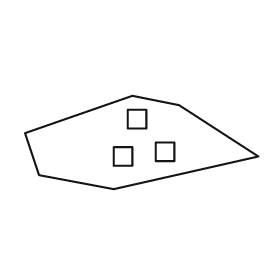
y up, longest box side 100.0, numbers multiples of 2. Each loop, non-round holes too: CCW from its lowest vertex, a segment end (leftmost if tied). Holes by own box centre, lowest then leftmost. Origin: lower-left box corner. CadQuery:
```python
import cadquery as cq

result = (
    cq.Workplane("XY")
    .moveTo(38.0, 0.0)
    .lineTo(100.0, 14.0)
    .lineTo(66.0, 36.0)
    .lineTo(46.0, 40.0)
    .lineTo(0.0, 24.0)
    .lineTo(6.0, 6.0)
    .close()
    .moveTo(38.0, 10.0)
    .lineTo(46.0, 10.0)
    .lineTo(46.0, 18.0)
    .lineTo(38.0, 18.0)
    .close()
    .moveTo(56.0, 12.0)
    .lineTo(64.0, 12.0)
    .lineTo(64.0, 20.0)
    .lineTo(56.0, 20.0)
    .close()
    .moveTo(44.0, 26.0)
    .lineTo(52.0, 26.0)
    .lineTo(52.0, 34.0)
    .lineTo(44.0, 34.0)
    .close()
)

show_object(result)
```